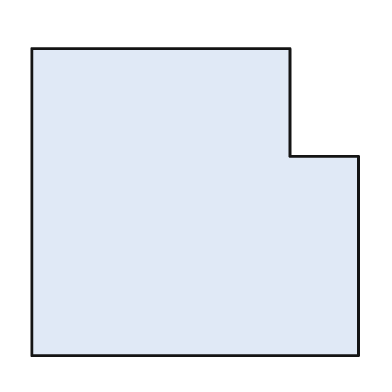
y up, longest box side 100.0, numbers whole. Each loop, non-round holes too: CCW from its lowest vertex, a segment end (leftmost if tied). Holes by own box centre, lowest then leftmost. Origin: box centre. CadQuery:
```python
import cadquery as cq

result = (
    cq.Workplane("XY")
    .moveTo(-50.0, -47.0)
    .lineTo(50.0, -47.0)
    .lineTo(50.0, 14.0)
    .lineTo(29.0, 14.0)
    .lineTo(29.0, 47.0)
    .lineTo(-50.0, 47.0)
    .close()
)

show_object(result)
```